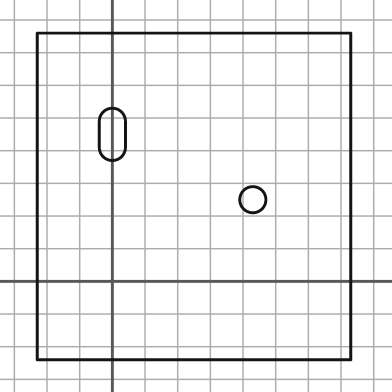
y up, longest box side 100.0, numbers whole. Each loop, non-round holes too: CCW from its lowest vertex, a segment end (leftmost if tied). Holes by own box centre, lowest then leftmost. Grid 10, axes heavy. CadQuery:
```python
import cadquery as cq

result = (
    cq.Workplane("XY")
    .moveTo(-23.0, -24.0)
    .lineTo(73.0, -24.0)
    .lineTo(73.0, 76.0)
    .lineTo(-23.0, 76.0)
    .close()
    .moveTo(43.0, 25.0)
    .circle(4.0)
    .moveTo(-4.0, 41.0)
    .threePointArc((0.0, 37.0), (4.0, 41.0))
    .lineTo(4.0, 49.0)
    .threePointArc((0.0, 53.0), (-4.0, 49.0))
    .close()
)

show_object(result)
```